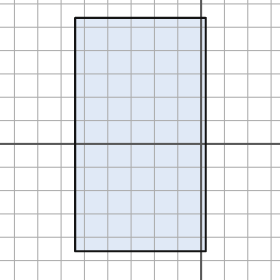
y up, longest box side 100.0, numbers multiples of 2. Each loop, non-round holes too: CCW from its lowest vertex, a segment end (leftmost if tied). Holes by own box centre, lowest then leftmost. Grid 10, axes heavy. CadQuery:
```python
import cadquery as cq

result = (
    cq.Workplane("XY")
    .moveTo(-54.0, -46.0)
    .lineTo(2.0, -46.0)
    .lineTo(2.0, 54.0)
    .lineTo(-54.0, 54.0)
    .close()
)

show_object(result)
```